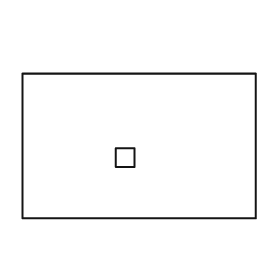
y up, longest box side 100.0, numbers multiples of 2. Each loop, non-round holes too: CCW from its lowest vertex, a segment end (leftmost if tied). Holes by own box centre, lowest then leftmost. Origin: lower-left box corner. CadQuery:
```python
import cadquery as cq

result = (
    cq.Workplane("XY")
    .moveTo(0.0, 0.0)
    .lineTo(100.0, 0.0)
    .lineTo(100.0, 62.0)
    .lineTo(0.0, 62.0)
    .close()
    .moveTo(40.0, 22.0)
    .lineTo(48.0, 22.0)
    .lineTo(48.0, 30.0)
    .lineTo(40.0, 30.0)
    .close()
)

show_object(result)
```